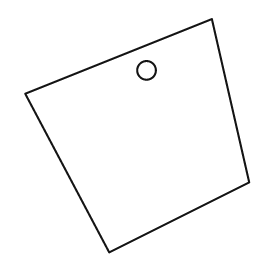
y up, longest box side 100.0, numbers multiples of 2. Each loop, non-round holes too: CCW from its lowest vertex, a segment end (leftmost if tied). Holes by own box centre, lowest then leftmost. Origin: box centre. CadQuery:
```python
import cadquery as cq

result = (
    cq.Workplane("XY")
    .moveTo(-12.0, -50.0)
    .lineTo(48.0, -20.0)
    .lineTo(32.0, 50.0)
    .lineTo(-48.0, 18.0)
    .close()
    .moveTo(4.0, 28.0)
    .circle(4.0)
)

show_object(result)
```